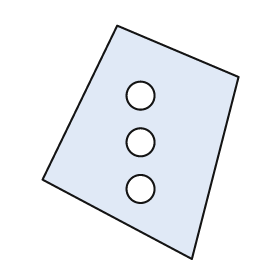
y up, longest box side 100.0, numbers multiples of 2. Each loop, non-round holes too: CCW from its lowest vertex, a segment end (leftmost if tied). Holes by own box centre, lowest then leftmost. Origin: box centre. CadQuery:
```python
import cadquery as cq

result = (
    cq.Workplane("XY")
    .moveTo(22.0, -50.0)
    .lineTo(42.0, 28.0)
    .lineTo(-10.0, 50.0)
    .lineTo(-42.0, -16.0)
    .close()
    .moveTo(0.0, -20.0)
    .circle(6.0)
    .moveTo(0.0, 0.0)
    .circle(6.0)
    .moveTo(0.0, 20.0)
    .circle(6.0)
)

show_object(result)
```